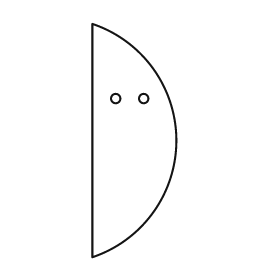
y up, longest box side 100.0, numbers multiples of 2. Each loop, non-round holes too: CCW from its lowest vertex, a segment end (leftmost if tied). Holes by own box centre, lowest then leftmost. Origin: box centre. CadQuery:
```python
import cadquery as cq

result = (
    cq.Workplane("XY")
    .moveTo(-18.0, -50.0)
    .threePointArc((18.0, 0.0), (-18.0, 50.0))
    .close()
    .moveTo(-8.0, 18.0)
    .circle(2.0)
    .moveTo(4.0, 18.0)
    .circle(2.0)
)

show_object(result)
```